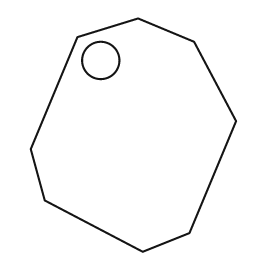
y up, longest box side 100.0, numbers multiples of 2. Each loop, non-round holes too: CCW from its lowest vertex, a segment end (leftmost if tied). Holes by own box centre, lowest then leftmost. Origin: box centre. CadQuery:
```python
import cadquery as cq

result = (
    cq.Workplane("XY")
    .moveTo(4.0, -50.0)
    .lineTo(24.0, -42.0)
    .lineTo(44.0, 6.0)
    .lineTo(26.0, 40.0)
    .lineTo(2.0, 50.0)
    .lineTo(-24.0, 42.0)
    .lineTo(-44.0, -6.0)
    .lineTo(-38.0, -28.0)
    .close()
    .moveTo(-14.0, 32.0)
    .circle(8.0)
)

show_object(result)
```